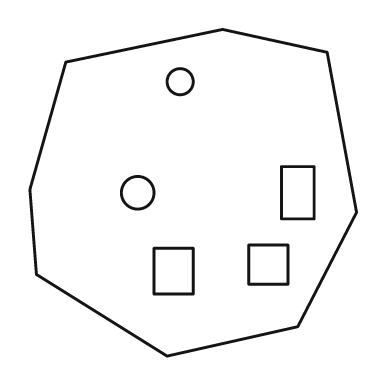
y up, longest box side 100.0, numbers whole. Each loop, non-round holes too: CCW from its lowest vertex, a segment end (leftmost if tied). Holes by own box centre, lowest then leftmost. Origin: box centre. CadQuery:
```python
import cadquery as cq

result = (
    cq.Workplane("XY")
    .moveTo(-8.0, -50.0)
    .lineTo(32.0, -41.0)
    .lineTo(50.0, -6.0)
    .lineTo(41.0, 43.0)
    .lineTo(9.0, 50.0)
    .lineTo(-39.0, 40.0)
    .lineTo(-50.0, 1.0)
    .lineTo(-48.0, -25.0)
    .close()
    .moveTo(-12.0, -31.0)
    .lineTo(0.0, -31.0)
    .lineTo(0.0, -17.0)
    .lineTo(-12.0, -17.0)
    .close()
    .moveTo(17.0, -28.0)
    .lineTo(29.0, -28.0)
    .lineTo(29.0, -16.0)
    .lineTo(17.0, -16.0)
    .close()
    .moveTo(-17.0, 0.0)
    .circle(5.0)
    .moveTo(27.0, -8.0)
    .lineTo(37.0, -8.0)
    .lineTo(37.0, 8.0)
    .lineTo(27.0, 8.0)
    .close()
    .moveTo(-4.0, 34.0)
    .circle(4.0)
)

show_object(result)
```